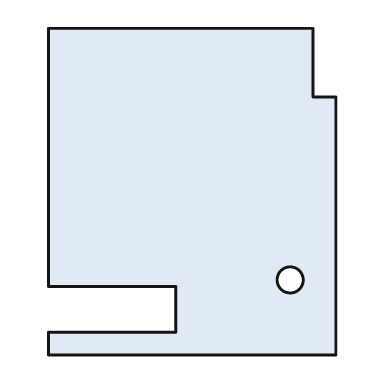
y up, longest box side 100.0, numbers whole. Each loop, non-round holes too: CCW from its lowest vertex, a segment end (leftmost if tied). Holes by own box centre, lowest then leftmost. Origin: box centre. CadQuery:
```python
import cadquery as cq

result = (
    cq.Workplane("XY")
    .moveTo(-44.0, -50.0)
    .lineTo(44.0, -50.0)
    .lineTo(44.0, 29.0)
    .lineTo(37.0, 29.0)
    .lineTo(37.0, 50.0)
    .lineTo(-44.0, 50.0)
    .lineTo(-44.0, -29.0)
    .lineTo(-5.0, -29.0)
    .lineTo(-5.0, -43.0)
    .lineTo(-44.0, -43.0)
    .close()
    .moveTo(30.0, -27.0)
    .circle(4.0)
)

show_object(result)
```